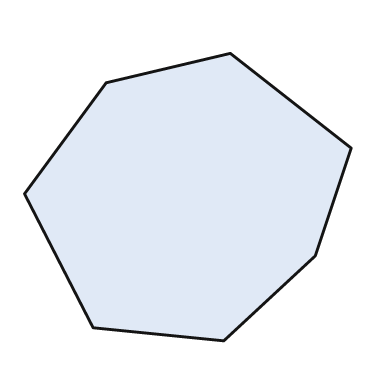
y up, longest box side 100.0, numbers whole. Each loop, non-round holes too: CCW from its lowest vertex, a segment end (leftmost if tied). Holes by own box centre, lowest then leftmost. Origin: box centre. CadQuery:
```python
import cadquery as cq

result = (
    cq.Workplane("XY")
    .moveTo(11.0, -44.0)
    .lineTo(39.0, -18.0)
    .lineTo(50.0, 15.0)
    .lineTo(13.0, 44.0)
    .lineTo(-25.0, 35.0)
    .lineTo(-50.0, 1.0)
    .lineTo(-29.0, -40.0)
    .close()
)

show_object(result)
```